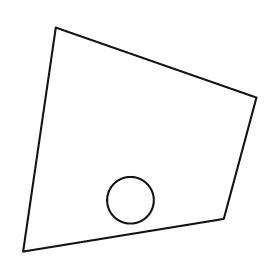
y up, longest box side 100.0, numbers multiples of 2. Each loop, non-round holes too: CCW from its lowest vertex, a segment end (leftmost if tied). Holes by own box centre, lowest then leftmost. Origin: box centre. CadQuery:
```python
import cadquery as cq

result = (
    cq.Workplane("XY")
    .moveTo(-50.0, -48.0)
    .lineTo(36.0, -34.0)
    .lineTo(50.0, 18.0)
    .lineTo(-36.0, 48.0)
    .close()
    .moveTo(-4.0, -26.0)
    .circle(10.0)
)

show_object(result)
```